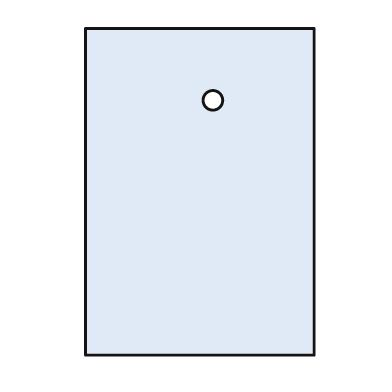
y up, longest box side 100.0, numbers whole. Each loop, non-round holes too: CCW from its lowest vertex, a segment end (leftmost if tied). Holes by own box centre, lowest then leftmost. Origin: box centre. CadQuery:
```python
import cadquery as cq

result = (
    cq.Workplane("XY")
    .moveTo(-35.0, -50.0)
    .lineTo(35.0, -50.0)
    .lineTo(35.0, 50.0)
    .lineTo(-35.0, 50.0)
    .close()
    .moveTo(4.0, 28.0)
    .circle(3.0)
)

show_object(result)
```